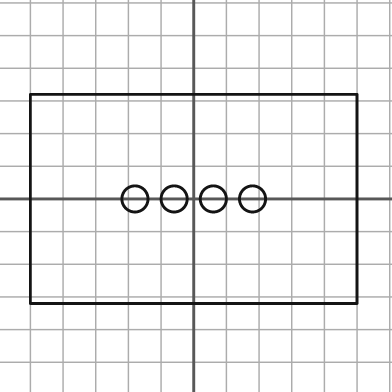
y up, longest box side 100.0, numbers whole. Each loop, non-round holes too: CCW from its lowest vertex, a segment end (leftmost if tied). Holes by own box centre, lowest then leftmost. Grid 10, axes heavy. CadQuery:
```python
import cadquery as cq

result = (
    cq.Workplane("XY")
    .moveTo(-50.0, -32.0)
    .lineTo(50.0, -32.0)
    .lineTo(50.0, 32.0)
    .lineTo(-50.0, 32.0)
    .close()
    .moveTo(-18.0, 0.0)
    .circle(4.0)
    .moveTo(-6.0, 0.0)
    .circle(4.0)
    .moveTo(6.0, 0.0)
    .circle(4.0)
    .moveTo(18.0, 0.0)
    .circle(4.0)
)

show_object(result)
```